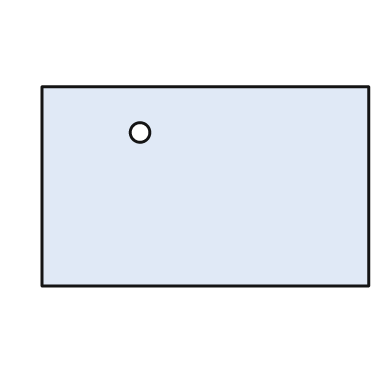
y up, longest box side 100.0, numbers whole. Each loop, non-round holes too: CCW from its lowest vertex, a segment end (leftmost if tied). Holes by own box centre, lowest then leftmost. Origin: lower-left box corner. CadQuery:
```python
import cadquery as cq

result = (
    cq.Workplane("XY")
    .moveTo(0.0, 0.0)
    .lineTo(100.0, 0.0)
    .lineTo(100.0, 61.0)
    .lineTo(0.0, 61.0)
    .close()
    .moveTo(30.0, 47.0)
    .circle(3.0)
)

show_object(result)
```